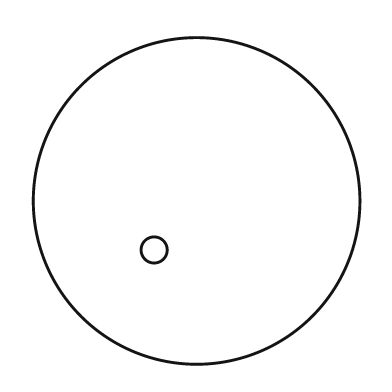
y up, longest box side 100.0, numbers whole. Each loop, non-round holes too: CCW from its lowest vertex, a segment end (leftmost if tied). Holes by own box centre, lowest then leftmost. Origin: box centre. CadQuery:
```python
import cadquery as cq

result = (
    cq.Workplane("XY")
    .moveTo(0.0, 0.0)
    .circle(50.0)
    .moveTo(-13.0, -15.0)
    .circle(4.0)
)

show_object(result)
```